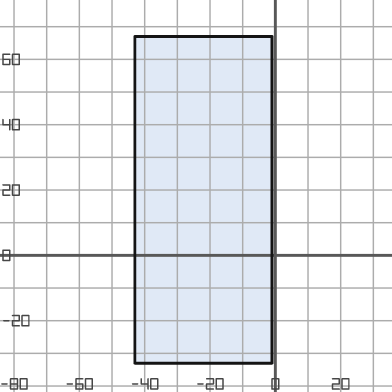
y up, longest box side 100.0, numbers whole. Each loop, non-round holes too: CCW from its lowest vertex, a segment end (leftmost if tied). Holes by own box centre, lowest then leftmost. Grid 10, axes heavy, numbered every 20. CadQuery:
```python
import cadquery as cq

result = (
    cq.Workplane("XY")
    .moveTo(-43.0, -33.0)
    .lineTo(-1.0, -33.0)
    .lineTo(-1.0, 67.0)
    .lineTo(-43.0, 67.0)
    .close()
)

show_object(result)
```